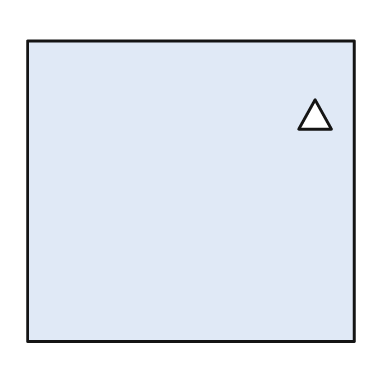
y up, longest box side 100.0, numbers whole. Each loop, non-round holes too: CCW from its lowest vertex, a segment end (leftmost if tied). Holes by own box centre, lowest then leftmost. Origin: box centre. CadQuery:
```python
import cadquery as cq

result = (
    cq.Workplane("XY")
    .moveTo(-50.0, -46.0)
    .lineTo(50.0, -46.0)
    .lineTo(50.0, 46.0)
    .lineTo(-50.0, 46.0)
    .close()
    .moveTo(33.0, 19.0)
    .lineTo(43.0, 19.0)
    .lineTo(38.0, 28.0)
    .close()
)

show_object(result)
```